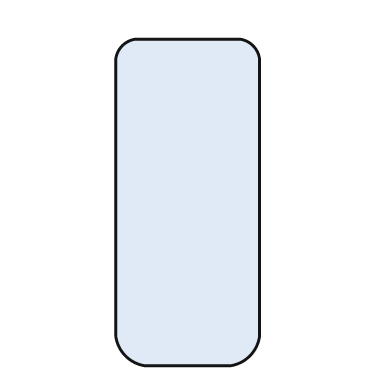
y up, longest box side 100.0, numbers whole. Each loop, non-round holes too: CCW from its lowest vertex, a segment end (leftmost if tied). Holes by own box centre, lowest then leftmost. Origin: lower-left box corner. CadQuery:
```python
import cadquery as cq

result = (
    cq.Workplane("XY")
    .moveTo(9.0, 0.0)
    .lineTo(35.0, 0.0)
    .threePointArc((41.0, 3.0), (44.0, 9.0))
    .lineTo(44.0, 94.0)
    .threePointArc((42.0, 98.0), (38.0, 100.0))
    .lineTo(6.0, 100.0)
    .threePointArc((2.0, 98.0), (0.0, 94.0))
    .lineTo(0.0, 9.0)
    .threePointArc((3.0, 3.0), (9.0, 0.0))
    .close()
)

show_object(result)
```